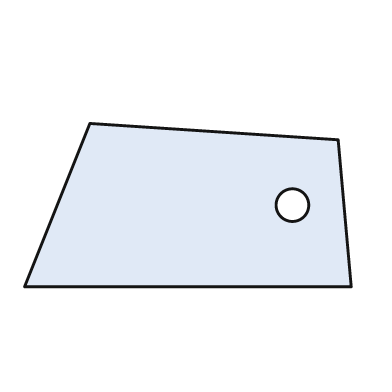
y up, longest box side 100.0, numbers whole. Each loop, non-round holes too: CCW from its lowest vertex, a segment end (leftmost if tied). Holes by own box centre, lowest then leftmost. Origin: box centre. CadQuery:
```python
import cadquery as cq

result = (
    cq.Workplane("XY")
    .moveTo(-50.0, -25.0)
    .lineTo(50.0, -25.0)
    .lineTo(46.0, 20.0)
    .lineTo(-30.0, 25.0)
    .close()
    .moveTo(32.0, 0.0)
    .circle(5.0)
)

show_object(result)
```